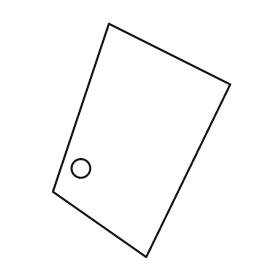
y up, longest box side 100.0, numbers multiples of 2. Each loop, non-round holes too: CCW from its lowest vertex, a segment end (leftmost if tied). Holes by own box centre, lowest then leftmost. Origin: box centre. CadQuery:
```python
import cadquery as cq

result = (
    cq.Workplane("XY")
    .moveTo(2.0, -50.0)
    .lineTo(38.0, 24.0)
    .lineTo(-14.0, 50.0)
    .lineTo(-38.0, -22.0)
    .close()
    .moveTo(-26.0, -12.0)
    .circle(4.0)
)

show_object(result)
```